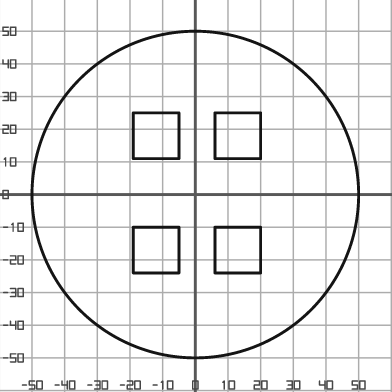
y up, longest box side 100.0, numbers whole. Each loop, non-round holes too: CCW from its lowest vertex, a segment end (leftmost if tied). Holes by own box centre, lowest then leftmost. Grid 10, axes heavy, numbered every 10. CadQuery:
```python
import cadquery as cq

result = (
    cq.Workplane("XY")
    .moveTo(0.0, 0.0)
    .circle(50.0)
    .moveTo(-19.0, -24.0)
    .lineTo(-5.0, -24.0)
    .lineTo(-5.0, -10.0)
    .lineTo(-19.0, -10.0)
    .close()
    .moveTo(6.0, -24.0)
    .lineTo(20.0, -24.0)
    .lineTo(20.0, -10.0)
    .lineTo(6.0, -10.0)
    .close()
    .moveTo(-19.0, 11.0)
    .lineTo(-5.0, 11.0)
    .lineTo(-5.0, 25.0)
    .lineTo(-19.0, 25.0)
    .close()
    .moveTo(6.0, 11.0)
    .lineTo(20.0, 11.0)
    .lineTo(20.0, 25.0)
    .lineTo(6.0, 25.0)
    .close()
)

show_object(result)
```